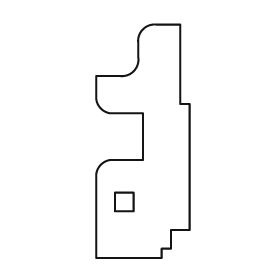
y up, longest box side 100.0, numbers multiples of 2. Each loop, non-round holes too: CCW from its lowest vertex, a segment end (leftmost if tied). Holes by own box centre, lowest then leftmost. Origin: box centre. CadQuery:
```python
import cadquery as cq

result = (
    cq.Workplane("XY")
    .moveTo(-20.0, -50.0)
    .lineTo(8.0, -50.0)
    .lineTo(8.0, -46.0)
    .lineTo(12.0, -46.0)
    .lineTo(12.0, -38.0)
    .lineTo(20.0, -38.0)
    .lineTo(20.0, 16.0)
    .lineTo(16.0, 16.0)
    .lineTo(16.0, 50.0)
    .lineTo(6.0, 50.0)
    .threePointArc((0.0, 48.0), (-2.0, 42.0))
    .lineTo(-2.0, 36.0)
    .threePointArc((-4.0, 30.0), (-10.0, 28.0))
    .lineTo(-20.0, 28.0)
    .lineTo(-20.0, 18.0)
    .threePointArc((-18.0, 14.0), (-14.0, 12.0))
    .lineTo(0.0, 12.0)
    .lineTo(0.0, -8.0)
    .lineTo(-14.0, -8.0)
    .threePointArc((-18.0, -10.0), (-20.0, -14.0))
    .close()
    .moveTo(-12.0, -30.0)
    .lineTo(-4.0, -30.0)
    .lineTo(-4.0, -22.0)
    .lineTo(-12.0, -22.0)
    .close()
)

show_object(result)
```